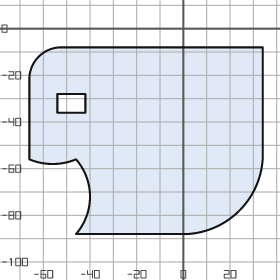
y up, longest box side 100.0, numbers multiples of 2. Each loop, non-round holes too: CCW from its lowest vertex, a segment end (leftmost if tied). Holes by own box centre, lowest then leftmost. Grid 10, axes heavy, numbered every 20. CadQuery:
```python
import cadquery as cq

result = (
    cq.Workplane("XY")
    .moveTo(-46.0, -88.0)
    .lineTo(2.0, -88.0)
    .threePointArc((24.0, -78.0), (34.0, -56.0))
    .lineTo(34.0, -8.0)
    .lineTo(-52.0, -8.0)
    .threePointArc((-62.0, -12.0), (-66.0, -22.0))
    .lineTo(-66.0, -56.0)
    .threePointArc((-56.0, -58.0), (-46.0, -56.0))
    .threePointArc((-40.0, -72.0), (-46.0, -88.0))
    .close()
    .moveTo(-54.0, -36.0)
    .lineTo(-42.0, -36.0)
    .lineTo(-42.0, -28.0)
    .lineTo(-54.0, -28.0)
    .close()
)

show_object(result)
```